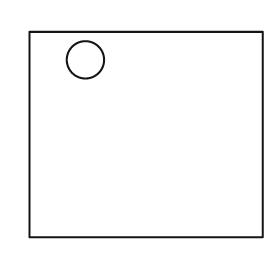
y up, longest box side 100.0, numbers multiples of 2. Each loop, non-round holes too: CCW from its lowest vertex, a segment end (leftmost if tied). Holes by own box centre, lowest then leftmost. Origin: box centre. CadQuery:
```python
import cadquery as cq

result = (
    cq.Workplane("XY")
    .moveTo(-50.0, -44.0)
    .lineTo(50.0, -44.0)
    .lineTo(50.0, 44.0)
    .lineTo(-50.0, 44.0)
    .close()
    .moveTo(-26.0, 32.0)
    .circle(8.0)
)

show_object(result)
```